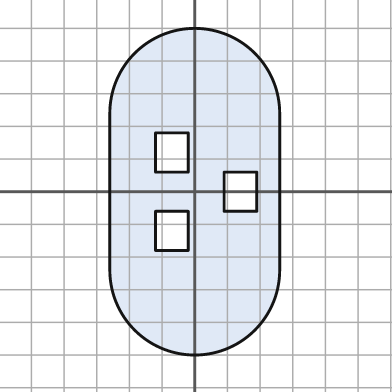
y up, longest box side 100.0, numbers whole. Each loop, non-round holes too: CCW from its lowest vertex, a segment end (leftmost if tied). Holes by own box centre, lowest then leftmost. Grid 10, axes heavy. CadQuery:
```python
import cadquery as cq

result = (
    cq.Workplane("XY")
    .moveTo(-26.0, -24.0)
    .threePointArc((0.0, -50.0), (26.0, -24.0))
    .lineTo(26.0, 24.0)
    .threePointArc((0.0, 50.0), (-26.0, 24.0))
    .close()
    .moveTo(-12.0, -18.0)
    .lineTo(-2.0, -18.0)
    .lineTo(-2.0, -6.0)
    .lineTo(-12.0, -6.0)
    .close()
    .moveTo(9.0, -6.0)
    .lineTo(19.0, -6.0)
    .lineTo(19.0, 6.0)
    .lineTo(9.0, 6.0)
    .close()
    .moveTo(-12.0, 6.0)
    .lineTo(-2.0, 6.0)
    .lineTo(-2.0, 18.0)
    .lineTo(-12.0, 18.0)
    .close()
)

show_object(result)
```